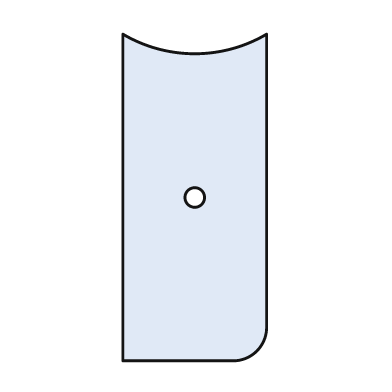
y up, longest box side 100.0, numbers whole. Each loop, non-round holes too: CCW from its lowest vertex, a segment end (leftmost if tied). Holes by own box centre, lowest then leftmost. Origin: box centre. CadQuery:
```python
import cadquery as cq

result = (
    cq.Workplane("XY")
    .moveTo(-22.0, -50.0)
    .lineTo(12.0, -50.0)
    .threePointArc((19.0, -47.0), (22.0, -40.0))
    .lineTo(22.0, 50.0)
    .threePointArc((0.0, 44.0), (-22.0, 50.0))
    .close()
    .moveTo(0.0, 0.0)
    .circle(3.0)
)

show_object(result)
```